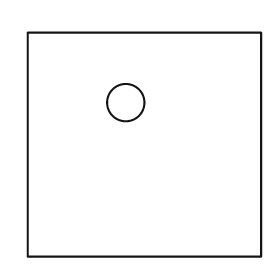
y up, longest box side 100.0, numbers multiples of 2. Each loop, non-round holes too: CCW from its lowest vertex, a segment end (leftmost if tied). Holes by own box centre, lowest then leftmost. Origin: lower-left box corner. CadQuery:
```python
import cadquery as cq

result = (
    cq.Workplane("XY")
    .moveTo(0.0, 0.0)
    .lineTo(100.0, 0.0)
    .lineTo(100.0, 96.0)
    .lineTo(0.0, 96.0)
    .close()
    .moveTo(42.0, 66.0)
    .circle(8.0)
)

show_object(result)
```